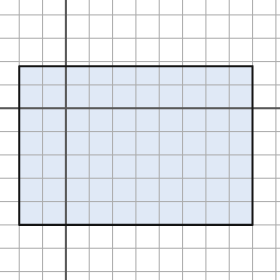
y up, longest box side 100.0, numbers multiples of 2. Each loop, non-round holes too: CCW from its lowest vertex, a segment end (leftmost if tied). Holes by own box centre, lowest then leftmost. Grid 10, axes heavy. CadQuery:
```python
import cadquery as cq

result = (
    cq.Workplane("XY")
    .moveTo(-20.0, -50.0)
    .lineTo(80.0, -50.0)
    .lineTo(80.0, 18.0)
    .lineTo(-20.0, 18.0)
    .close()
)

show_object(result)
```